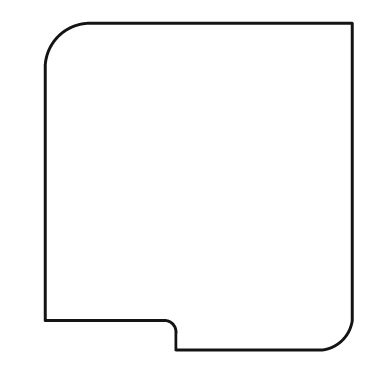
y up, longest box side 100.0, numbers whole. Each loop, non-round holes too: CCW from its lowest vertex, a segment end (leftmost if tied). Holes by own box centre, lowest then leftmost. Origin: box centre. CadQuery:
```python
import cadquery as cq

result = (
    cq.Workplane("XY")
    .moveTo(-7.0, -50.0)
    .lineTo(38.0, -50.0)
    .threePointArc((44.0, -47.0), (47.0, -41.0))
    .lineTo(47.0, 50.0)
    .lineTo(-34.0, 50.0)
    .threePointArc((-43.0, 46.0), (-47.0, 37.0))
    .lineTo(-47.0, -41.0)
    .lineTo(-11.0, -41.0)
    .threePointArc((-8.0, -42.0), (-7.0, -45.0))
    .close()
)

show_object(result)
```